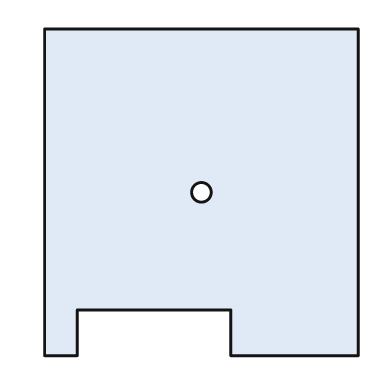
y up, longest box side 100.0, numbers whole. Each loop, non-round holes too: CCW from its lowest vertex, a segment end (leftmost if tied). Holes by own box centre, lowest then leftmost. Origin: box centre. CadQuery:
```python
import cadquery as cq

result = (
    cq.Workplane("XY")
    .moveTo(-48.0, -50.0)
    .lineTo(-38.0, -50.0)
    .lineTo(-38.0, -36.0)
    .lineTo(9.0, -36.0)
    .lineTo(9.0, -50.0)
    .lineTo(48.0, -50.0)
    .lineTo(48.0, 50.0)
    .lineTo(-48.0, 50.0)
    .close()
    .moveTo(0.0, 0.0)
    .circle(3.0)
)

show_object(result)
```